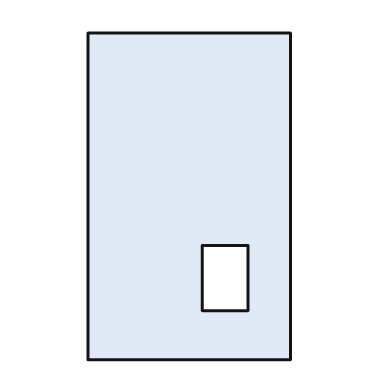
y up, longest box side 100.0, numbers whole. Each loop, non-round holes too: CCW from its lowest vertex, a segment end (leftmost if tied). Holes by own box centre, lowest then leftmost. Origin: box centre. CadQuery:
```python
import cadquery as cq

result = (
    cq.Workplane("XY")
    .moveTo(-31.0, -50.0)
    .lineTo(31.0, -50.0)
    .lineTo(31.0, 50.0)
    .lineTo(-31.0, 50.0)
    .close()
    .moveTo(4.0, -35.0)
    .lineTo(18.0, -35.0)
    .lineTo(18.0, -15.0)
    .lineTo(4.0, -15.0)
    .close()
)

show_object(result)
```